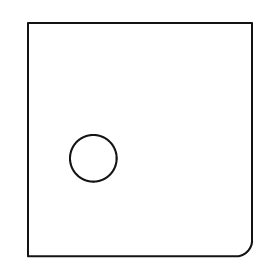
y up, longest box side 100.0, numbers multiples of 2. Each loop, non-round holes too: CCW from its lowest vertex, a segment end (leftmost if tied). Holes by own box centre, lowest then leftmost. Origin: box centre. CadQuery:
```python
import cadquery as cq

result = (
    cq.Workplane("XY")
    .moveTo(-48.0, -50.0)
    .lineTo(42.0, -50.0)
    .threePointArc((46.0, -48.0), (48.0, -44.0))
    .lineTo(48.0, 50.0)
    .lineTo(-48.0, 50.0)
    .close()
    .moveTo(-20.0, -8.0)
    .circle(10.0)
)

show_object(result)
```